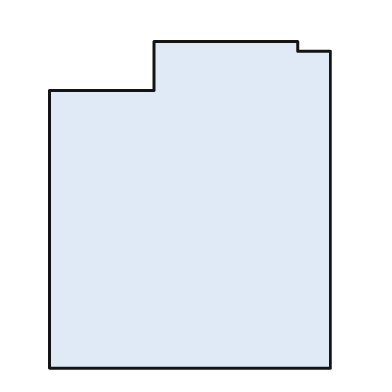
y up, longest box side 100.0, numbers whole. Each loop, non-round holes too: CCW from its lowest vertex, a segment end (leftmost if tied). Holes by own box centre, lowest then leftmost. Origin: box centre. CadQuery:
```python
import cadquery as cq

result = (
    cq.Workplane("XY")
    .moveTo(-43.0, -50.0)
    .lineTo(43.0, -50.0)
    .lineTo(43.0, 47.0)
    .lineTo(33.0, 47.0)
    .lineTo(33.0, 50.0)
    .lineTo(-11.0, 50.0)
    .lineTo(-11.0, 35.0)
    .lineTo(-43.0, 35.0)
    .close()
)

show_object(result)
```